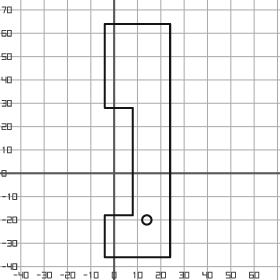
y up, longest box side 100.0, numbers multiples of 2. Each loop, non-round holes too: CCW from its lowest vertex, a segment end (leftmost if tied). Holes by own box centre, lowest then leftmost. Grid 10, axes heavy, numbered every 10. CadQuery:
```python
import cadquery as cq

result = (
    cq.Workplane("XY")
    .moveTo(-4.0, -36.0)
    .lineTo(24.0, -36.0)
    .lineTo(24.0, 64.0)
    .lineTo(-4.0, 64.0)
    .lineTo(-4.0, 28.0)
    .lineTo(8.0, 28.0)
    .lineTo(8.0, -18.0)
    .lineTo(-4.0, -18.0)
    .close()
    .moveTo(14.0, -20.0)
    .circle(2.0)
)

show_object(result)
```